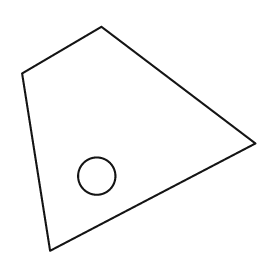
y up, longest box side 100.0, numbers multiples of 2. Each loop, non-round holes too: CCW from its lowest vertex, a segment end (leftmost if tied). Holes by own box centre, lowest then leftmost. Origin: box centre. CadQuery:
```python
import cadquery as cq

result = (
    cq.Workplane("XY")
    .moveTo(-38.0, -48.0)
    .lineTo(50.0, -2.0)
    .lineTo(-16.0, 48.0)
    .lineTo(-50.0, 28.0)
    .close()
    .moveTo(-18.0, -16.0)
    .circle(8.0)
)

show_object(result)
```